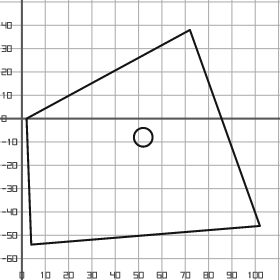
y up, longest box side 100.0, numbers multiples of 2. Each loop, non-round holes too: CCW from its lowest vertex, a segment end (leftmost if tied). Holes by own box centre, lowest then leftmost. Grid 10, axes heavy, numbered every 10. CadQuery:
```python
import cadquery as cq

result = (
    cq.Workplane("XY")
    .moveTo(4.0, -54.0)
    .lineTo(102.0, -46.0)
    .lineTo(72.0, 38.0)
    .lineTo(2.0, 0.0)
    .close()
    .moveTo(52.0, -8.0)
    .circle(4.0)
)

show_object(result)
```